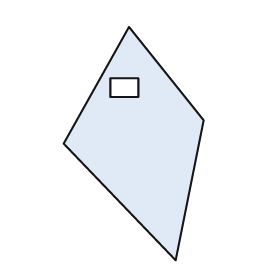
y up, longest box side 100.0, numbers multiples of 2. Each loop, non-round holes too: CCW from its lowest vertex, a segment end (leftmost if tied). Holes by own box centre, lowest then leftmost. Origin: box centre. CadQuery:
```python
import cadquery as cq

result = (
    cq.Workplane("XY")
    .moveTo(18.0, -50.0)
    .lineTo(30.0, 10.0)
    .lineTo(-2.0, 50.0)
    .lineTo(-30.0, 0.0)
    .close()
    .moveTo(-10.0, 20.0)
    .lineTo(2.0, 20.0)
    .lineTo(2.0, 28.0)
    .lineTo(-10.0, 28.0)
    .close()
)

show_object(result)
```